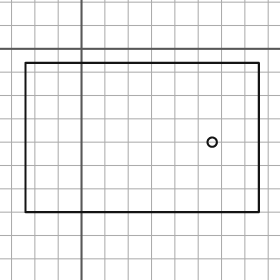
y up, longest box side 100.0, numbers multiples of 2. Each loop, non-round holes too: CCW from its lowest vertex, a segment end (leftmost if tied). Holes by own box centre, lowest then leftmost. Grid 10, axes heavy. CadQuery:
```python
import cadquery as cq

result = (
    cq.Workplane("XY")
    .moveTo(-24.0, -70.0)
    .lineTo(76.0, -70.0)
    .lineTo(76.0, -6.0)
    .lineTo(-24.0, -6.0)
    .close()
    .moveTo(56.0, -40.0)
    .circle(2.0)
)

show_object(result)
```